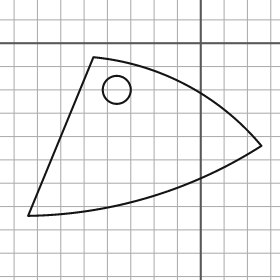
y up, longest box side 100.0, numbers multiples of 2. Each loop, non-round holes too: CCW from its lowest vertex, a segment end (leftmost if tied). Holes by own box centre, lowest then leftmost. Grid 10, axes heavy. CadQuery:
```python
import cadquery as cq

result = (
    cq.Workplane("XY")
    .moveTo(-74.0, -74.0)
    .threePointArc((-22.0, -66.0), (26.0, -44.0))
    .threePointArc((-6.0, -18.0), (-46.0, -6.0))
    .close()
    .moveTo(-36.0, -20.0)
    .circle(6.0)
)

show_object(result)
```